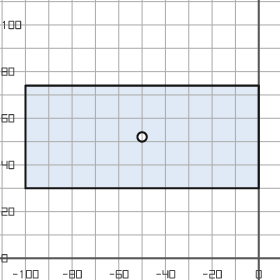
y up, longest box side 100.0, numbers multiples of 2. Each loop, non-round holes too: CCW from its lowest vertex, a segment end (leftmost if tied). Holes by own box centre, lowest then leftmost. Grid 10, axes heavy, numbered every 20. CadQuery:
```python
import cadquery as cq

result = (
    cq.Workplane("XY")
    .moveTo(-100.0, 30.0)
    .lineTo(0.0, 30.0)
    .lineTo(0.0, 74.0)
    .lineTo(-100.0, 74.0)
    .close()
    .moveTo(-50.0, 52.0)
    .circle(2.0)
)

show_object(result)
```